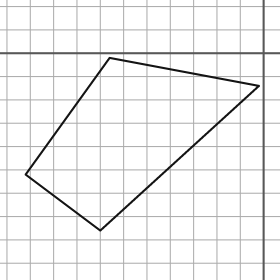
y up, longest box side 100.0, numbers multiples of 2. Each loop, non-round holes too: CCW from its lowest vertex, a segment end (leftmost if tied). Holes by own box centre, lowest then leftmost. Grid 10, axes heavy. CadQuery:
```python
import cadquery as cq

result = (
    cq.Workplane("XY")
    .moveTo(-70.0, -76.0)
    .lineTo(-2.0, -14.0)
    .lineTo(-66.0, -2.0)
    .lineTo(-102.0, -52.0)
    .close()
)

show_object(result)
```